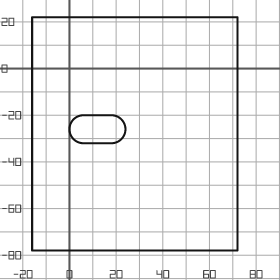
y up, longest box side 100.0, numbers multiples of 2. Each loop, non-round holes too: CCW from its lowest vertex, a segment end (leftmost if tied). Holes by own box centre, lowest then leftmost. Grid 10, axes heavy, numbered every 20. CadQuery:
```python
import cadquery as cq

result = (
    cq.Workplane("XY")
    .moveTo(-16.0, -78.0)
    .lineTo(72.0, -78.0)
    .lineTo(72.0, 22.0)
    .lineTo(-16.0, 22.0)
    .close()
    .moveTo(6.0, -32.0)
    .lineTo(18.0, -32.0)
    .threePointArc((24.0, -26.0), (18.0, -20.0))
    .lineTo(6.0, -20.0)
    .threePointArc((0.0, -26.0), (6.0, -32.0))
    .close()
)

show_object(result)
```